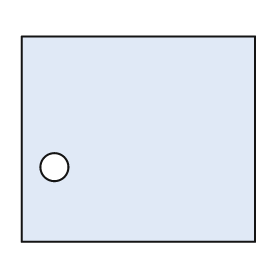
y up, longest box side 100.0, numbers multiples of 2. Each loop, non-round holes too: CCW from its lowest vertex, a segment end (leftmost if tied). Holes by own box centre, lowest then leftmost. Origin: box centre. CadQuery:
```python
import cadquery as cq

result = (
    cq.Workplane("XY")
    .moveTo(-50.0, -44.0)
    .lineTo(50.0, -44.0)
    .lineTo(50.0, 44.0)
    .lineTo(-50.0, 44.0)
    .close()
    .moveTo(-36.0, -12.0)
    .circle(6.0)
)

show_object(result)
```